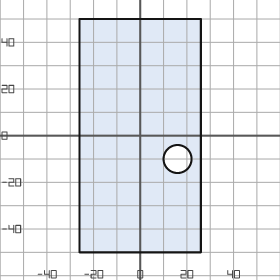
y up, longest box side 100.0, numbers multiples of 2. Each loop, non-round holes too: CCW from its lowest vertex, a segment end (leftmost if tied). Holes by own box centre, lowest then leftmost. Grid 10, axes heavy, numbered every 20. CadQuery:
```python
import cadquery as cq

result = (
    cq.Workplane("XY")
    .moveTo(-26.0, -50.0)
    .lineTo(26.0, -50.0)
    .lineTo(26.0, 50.0)
    .lineTo(-26.0, 50.0)
    .close()
    .moveTo(16.0, -10.0)
    .circle(6.0)
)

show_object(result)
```